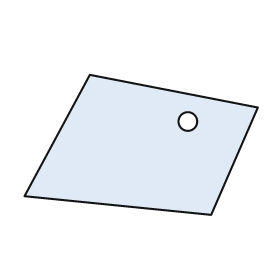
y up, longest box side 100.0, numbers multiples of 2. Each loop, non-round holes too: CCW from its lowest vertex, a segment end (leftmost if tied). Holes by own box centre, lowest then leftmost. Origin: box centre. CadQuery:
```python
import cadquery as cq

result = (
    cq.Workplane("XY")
    .moveTo(30.0, -30.0)
    .lineTo(50.0, 16.0)
    .lineTo(-22.0, 30.0)
    .lineTo(-50.0, -22.0)
    .close()
    .moveTo(20.0, 10.0)
    .circle(4.0)
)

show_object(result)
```